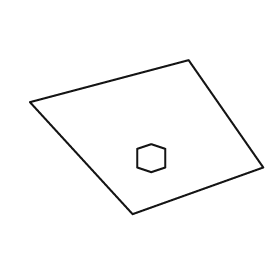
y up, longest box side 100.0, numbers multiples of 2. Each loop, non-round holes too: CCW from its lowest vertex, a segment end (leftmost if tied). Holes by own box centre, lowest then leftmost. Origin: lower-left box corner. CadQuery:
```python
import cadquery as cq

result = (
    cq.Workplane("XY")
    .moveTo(44.0, 0.0)
    .lineTo(100.0, 20.0)
    .lineTo(68.0, 66.0)
    .lineTo(0.0, 48.0)
    .close()
    .moveTo(52.0, 18.0)
    .lineTo(58.0, 20.0)
    .lineTo(58.0, 28.0)
    .lineTo(52.0, 30.0)
    .lineTo(46.0, 28.0)
    .lineTo(46.0, 20.0)
    .close()
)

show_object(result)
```